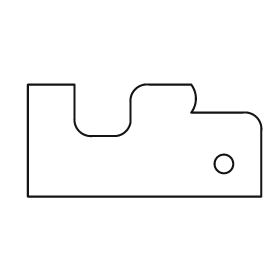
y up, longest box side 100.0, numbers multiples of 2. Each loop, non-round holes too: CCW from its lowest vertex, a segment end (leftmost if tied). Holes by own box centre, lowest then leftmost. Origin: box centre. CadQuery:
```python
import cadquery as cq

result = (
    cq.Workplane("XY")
    .moveTo(-50.0, -24.0)
    .lineTo(50.0, -24.0)
    .lineTo(50.0, 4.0)
    .threePointArc((48.0, 10.0), (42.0, 12.0))
    .lineTo(20.0, 12.0)
    .threePointArc((22.0, 18.0), (20.0, 24.0))
    .lineTo(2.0, 24.0)
    .threePointArc((-4.0, 22.0), (-6.0, 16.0))
    .lineTo(-6.0, 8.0)
    .threePointArc((-8.0, 4.0), (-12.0, 2.0))
    .lineTo(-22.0, 2.0)
    .threePointArc((-28.0, 4.0), (-30.0, 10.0))
    .lineTo(-30.0, 24.0)
    .lineTo(-50.0, 24.0)
    .close()
    .moveTo(34.0, -10.0)
    .circle(4.0)
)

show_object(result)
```